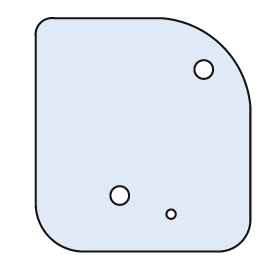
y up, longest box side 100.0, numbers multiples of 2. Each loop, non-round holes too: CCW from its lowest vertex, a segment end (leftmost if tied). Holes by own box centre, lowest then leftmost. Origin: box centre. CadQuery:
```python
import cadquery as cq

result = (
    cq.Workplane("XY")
    .moveTo(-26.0, -50.0)
    .lineTo(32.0, -50.0)
    .threePointArc((42.0, -46.0), (46.0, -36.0))
    .lineTo(46.0, 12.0)
    .threePointArc((34.0, 38.0), (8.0, 50.0))
    .lineTo(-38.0, 50.0)
    .threePointArc((-44.0, 48.0), (-46.0, 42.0))
    .lineTo(-46.0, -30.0)
    .threePointArc((-40.0, -44.0), (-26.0, -50.0))
    .close()
    .moveTo(12.0, -34.0)
    .circle(2.0)
    .moveTo(-10.0, -26.0)
    .circle(4.0)
    .moveTo(26.0, 28.0)
    .circle(4.0)
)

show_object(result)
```